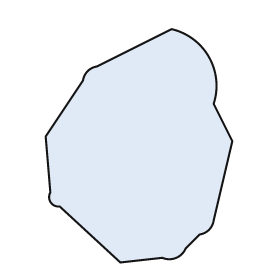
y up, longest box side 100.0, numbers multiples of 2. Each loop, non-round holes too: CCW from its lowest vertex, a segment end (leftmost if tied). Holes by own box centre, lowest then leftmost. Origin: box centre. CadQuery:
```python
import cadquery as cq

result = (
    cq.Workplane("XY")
    .moveTo(-8.0, -50.0)
    .lineTo(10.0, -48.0)
    .threePointArc((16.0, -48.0), (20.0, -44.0))
    .lineTo(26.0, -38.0)
    .threePointArc((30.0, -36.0), (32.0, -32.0))
    .lineTo(40.0, 2.0)
    .lineTo(32.0, 18.0)
    .threePointArc((30.0, 38.0), (14.0, 50.0))
    .lineTo(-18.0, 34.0)
    .threePointArc((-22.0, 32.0), (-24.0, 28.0))
    .lineTo(-40.0, 4.0)
    .lineTo(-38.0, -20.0)
    .threePointArc((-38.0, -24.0), (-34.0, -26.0))
    .close()
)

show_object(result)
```